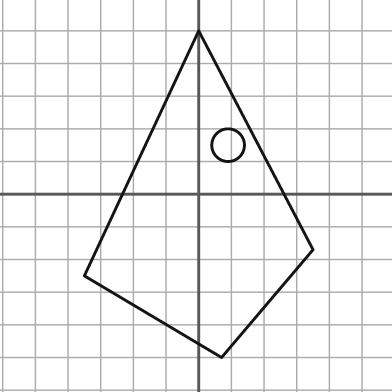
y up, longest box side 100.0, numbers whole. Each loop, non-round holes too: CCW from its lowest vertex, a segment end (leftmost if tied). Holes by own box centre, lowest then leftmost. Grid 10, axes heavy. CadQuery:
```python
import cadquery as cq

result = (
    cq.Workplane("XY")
    .moveTo(7.0, -50.0)
    .lineTo(35.0, -17.0)
    .lineTo(0.0, 50.0)
    .lineTo(-35.0, -25.0)
    .close()
    .moveTo(9.0, 15.0)
    .circle(5.0)
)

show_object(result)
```